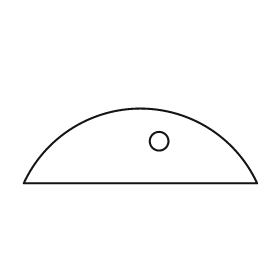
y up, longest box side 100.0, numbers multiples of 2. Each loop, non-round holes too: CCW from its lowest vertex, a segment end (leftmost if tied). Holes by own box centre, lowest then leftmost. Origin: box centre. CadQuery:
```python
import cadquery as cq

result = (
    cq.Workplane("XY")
    .moveTo(-50.0, -16.0)
    .lineTo(50.0, -16.0)
    .threePointArc((0.0, 16.0), (-50.0, -16.0))
    .close()
    .moveTo(8.0, 2.0)
    .circle(4.0)
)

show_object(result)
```